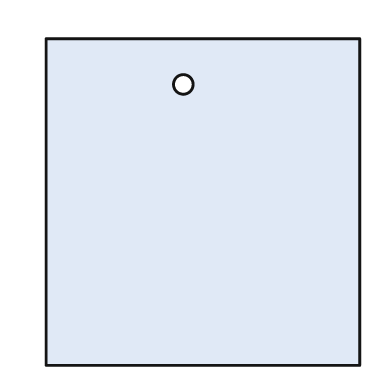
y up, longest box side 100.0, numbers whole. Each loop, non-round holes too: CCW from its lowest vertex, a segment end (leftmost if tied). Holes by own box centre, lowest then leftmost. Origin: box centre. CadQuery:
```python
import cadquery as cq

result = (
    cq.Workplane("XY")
    .moveTo(-48.0, -50.0)
    .lineTo(48.0, -50.0)
    .lineTo(48.0, 50.0)
    .lineTo(-48.0, 50.0)
    .close()
    .moveTo(-6.0, 36.0)
    .circle(3.0)
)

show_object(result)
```